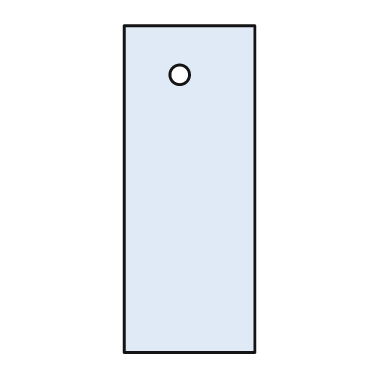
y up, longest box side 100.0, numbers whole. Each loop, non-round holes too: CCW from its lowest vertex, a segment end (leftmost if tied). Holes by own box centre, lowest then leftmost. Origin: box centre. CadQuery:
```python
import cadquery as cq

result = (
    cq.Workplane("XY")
    .moveTo(-20.0, -50.0)
    .lineTo(20.0, -50.0)
    .lineTo(20.0, 50.0)
    .lineTo(-20.0, 50.0)
    .close()
    .moveTo(-3.0, 35.0)
    .circle(3.0)
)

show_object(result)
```